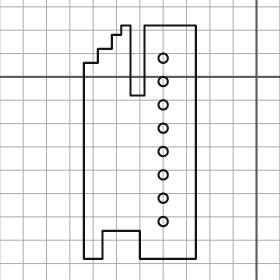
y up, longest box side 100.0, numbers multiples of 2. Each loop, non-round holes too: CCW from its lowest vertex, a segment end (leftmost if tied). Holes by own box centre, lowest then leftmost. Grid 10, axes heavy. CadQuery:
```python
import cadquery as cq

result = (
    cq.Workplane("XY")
    .moveTo(-74.0, -78.0)
    .lineTo(-66.0, -78.0)
    .lineTo(-66.0, -66.0)
    .lineTo(-50.0, -66.0)
    .lineTo(-50.0, -78.0)
    .lineTo(-26.0, -78.0)
    .lineTo(-26.0, 22.0)
    .lineTo(-48.0, 22.0)
    .lineTo(-48.0, -8.0)
    .lineTo(-54.0, -8.0)
    .lineTo(-54.0, 22.0)
    .lineTo(-58.0, 22.0)
    .lineTo(-58.0, 18.0)
    .lineTo(-62.0, 18.0)
    .lineTo(-62.0, 12.0)
    .lineTo(-68.0, 12.0)
    .lineTo(-68.0, 6.0)
    .lineTo(-74.0, 6.0)
    .close()
    .moveTo(-40.0, -62.0)
    .circle(2.0)
    .moveTo(-40.0, -52.0)
    .circle(2.0)
    .moveTo(-40.0, -42.0)
    .circle(2.0)
    .moveTo(-40.0, -32.0)
    .circle(2.0)
    .moveTo(-40.0, -22.0)
    .circle(2.0)
    .moveTo(-40.0, -12.0)
    .circle(2.0)
    .moveTo(-40.0, -2.0)
    .circle(2.0)
    .moveTo(-40.0, 8.0)
    .circle(2.0)
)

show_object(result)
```